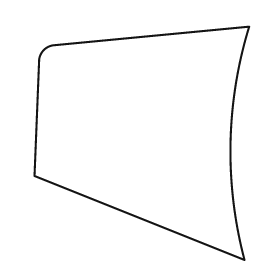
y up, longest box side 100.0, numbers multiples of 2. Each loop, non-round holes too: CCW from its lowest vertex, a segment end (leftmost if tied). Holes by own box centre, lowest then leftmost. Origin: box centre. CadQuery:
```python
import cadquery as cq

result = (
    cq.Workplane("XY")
    .moveTo(44.0, -50.0)
    .threePointArc((38.0, 0.0), (46.0, 50.0))
    .lineTo(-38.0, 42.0)
    .threePointArc((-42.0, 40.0), (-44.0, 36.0))
    .lineTo(-46.0, -14.0)
    .close()
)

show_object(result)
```